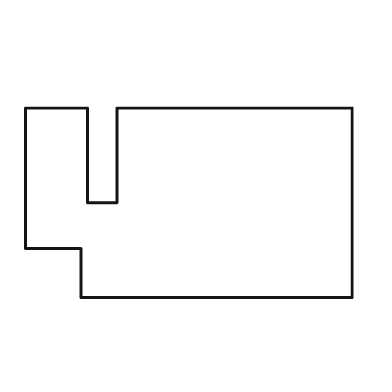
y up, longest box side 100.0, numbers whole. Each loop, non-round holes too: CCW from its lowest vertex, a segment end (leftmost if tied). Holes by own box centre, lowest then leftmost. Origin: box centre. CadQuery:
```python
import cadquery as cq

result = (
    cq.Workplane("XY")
    .moveTo(-33.0, -29.0)
    .lineTo(50.0, -29.0)
    .lineTo(50.0, 29.0)
    .lineTo(-22.0, 29.0)
    .lineTo(-22.0, 0.0)
    .lineTo(-31.0, 0.0)
    .lineTo(-31.0, 29.0)
    .lineTo(-50.0, 29.0)
    .lineTo(-50.0, -14.0)
    .lineTo(-33.0, -14.0)
    .close()
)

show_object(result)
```